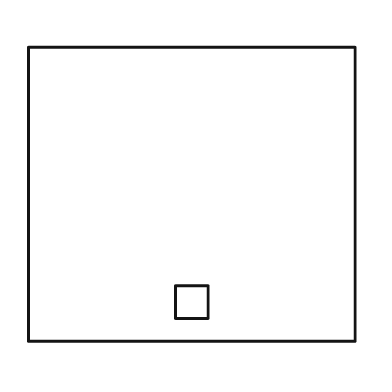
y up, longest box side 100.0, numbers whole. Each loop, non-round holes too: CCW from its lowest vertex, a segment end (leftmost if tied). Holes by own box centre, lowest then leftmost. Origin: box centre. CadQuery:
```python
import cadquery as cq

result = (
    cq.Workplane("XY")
    .moveTo(-50.0, -45.0)
    .lineTo(50.0, -45.0)
    .lineTo(50.0, 45.0)
    .lineTo(-50.0, 45.0)
    .close()
    .moveTo(-5.0, -38.0)
    .lineTo(5.0, -38.0)
    .lineTo(5.0, -28.0)
    .lineTo(-5.0, -28.0)
    .close()
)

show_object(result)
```